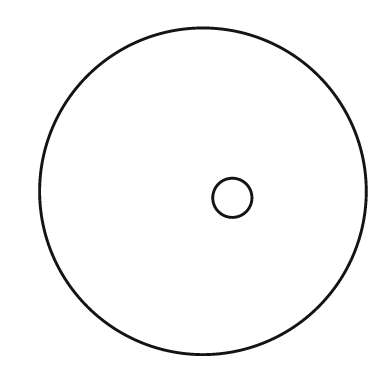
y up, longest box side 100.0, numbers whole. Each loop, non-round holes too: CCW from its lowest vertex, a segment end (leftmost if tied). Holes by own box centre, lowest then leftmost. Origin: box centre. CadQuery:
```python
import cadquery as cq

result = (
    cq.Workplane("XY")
    .moveTo(0.0, 0.0)
    .circle(50.0)
    .moveTo(9.0, -2.0)
    .circle(6.0)
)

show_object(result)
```